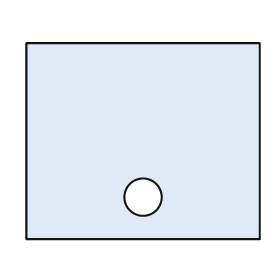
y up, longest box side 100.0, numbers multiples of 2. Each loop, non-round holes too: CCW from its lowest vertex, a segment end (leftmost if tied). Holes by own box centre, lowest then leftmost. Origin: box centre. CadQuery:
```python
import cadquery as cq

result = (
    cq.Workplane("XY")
    .moveTo(-50.0, -42.0)
    .lineTo(50.0, -42.0)
    .lineTo(50.0, 42.0)
    .lineTo(-50.0, 42.0)
    .close()
    .moveTo(0.0, -24.0)
    .circle(8.0)
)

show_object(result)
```